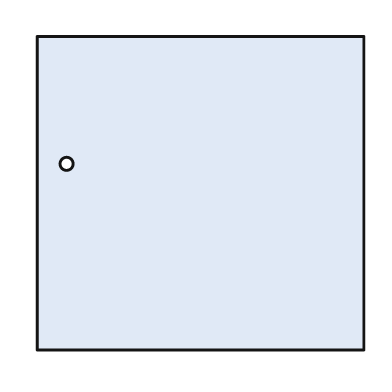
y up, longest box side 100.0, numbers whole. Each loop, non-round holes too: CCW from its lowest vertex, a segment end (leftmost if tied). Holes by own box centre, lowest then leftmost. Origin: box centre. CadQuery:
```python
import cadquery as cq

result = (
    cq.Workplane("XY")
    .moveTo(-50.0, -48.0)
    .lineTo(50.0, -48.0)
    .lineTo(50.0, 48.0)
    .lineTo(-50.0, 48.0)
    .close()
    .moveTo(-41.0, 9.0)
    .circle(2.0)
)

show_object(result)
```